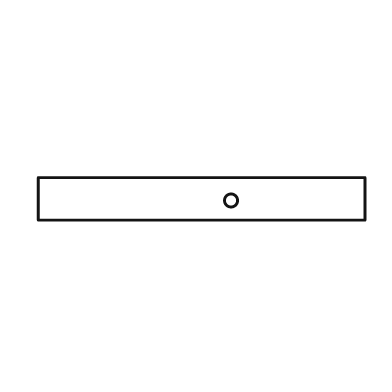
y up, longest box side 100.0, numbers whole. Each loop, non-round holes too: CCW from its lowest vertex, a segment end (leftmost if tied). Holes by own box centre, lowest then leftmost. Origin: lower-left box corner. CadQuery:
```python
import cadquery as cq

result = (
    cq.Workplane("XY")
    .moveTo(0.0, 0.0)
    .lineTo(100.0, 0.0)
    .lineTo(100.0, 13.0)
    .lineTo(0.0, 13.0)
    .close()
    .moveTo(59.0, 6.0)
    .circle(2.0)
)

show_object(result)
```